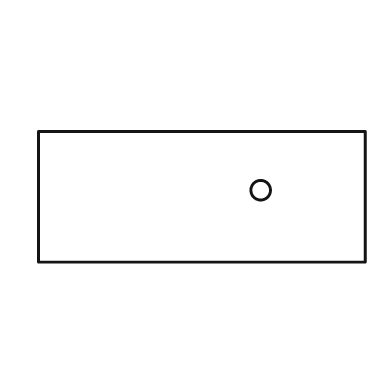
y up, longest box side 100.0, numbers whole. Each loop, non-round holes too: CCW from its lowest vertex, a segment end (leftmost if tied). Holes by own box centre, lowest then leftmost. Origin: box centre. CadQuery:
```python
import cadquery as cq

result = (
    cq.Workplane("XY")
    .moveTo(-50.0, -20.0)
    .lineTo(50.0, -20.0)
    .lineTo(50.0, 20.0)
    .lineTo(-50.0, 20.0)
    .close()
    .moveTo(18.0, 2.0)
    .circle(3.0)
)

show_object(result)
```